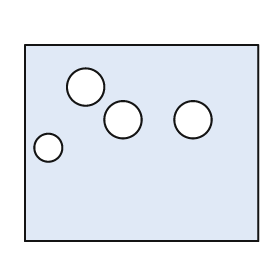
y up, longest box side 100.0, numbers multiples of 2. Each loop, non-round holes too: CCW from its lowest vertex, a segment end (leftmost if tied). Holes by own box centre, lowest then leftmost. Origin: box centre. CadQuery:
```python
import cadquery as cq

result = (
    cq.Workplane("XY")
    .moveTo(-50.0, -42.0)
    .lineTo(50.0, -42.0)
    .lineTo(50.0, 42.0)
    .lineTo(-50.0, 42.0)
    .close()
    .moveTo(-40.0, -2.0)
    .circle(6.0)
    .moveTo(-8.0, 10.0)
    .circle(8.0)
    .moveTo(22.0, 10.0)
    .circle(8.0)
    .moveTo(-24.0, 24.0)
    .circle(8.0)
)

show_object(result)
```